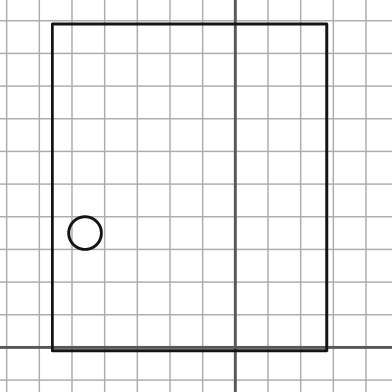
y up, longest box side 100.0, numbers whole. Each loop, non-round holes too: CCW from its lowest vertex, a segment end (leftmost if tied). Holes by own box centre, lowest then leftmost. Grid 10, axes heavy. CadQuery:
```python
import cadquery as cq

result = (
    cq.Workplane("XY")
    .moveTo(-56.0, -1.0)
    .lineTo(28.0, -1.0)
    .lineTo(28.0, 99.0)
    .lineTo(-56.0, 99.0)
    .close()
    .moveTo(-46.0, 35.0)
    .circle(5.0)
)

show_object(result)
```